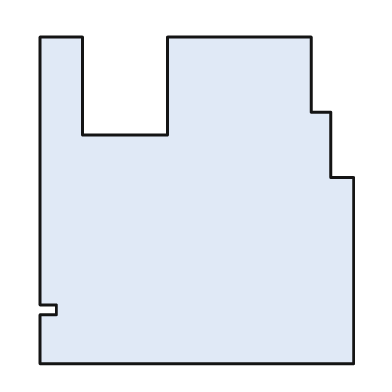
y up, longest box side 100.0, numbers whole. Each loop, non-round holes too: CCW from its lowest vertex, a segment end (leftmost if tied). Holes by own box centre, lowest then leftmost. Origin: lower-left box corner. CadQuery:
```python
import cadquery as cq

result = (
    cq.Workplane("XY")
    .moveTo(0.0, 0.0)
    .lineTo(96.0, 0.0)
    .lineTo(96.0, 57.0)
    .lineTo(89.0, 57.0)
    .lineTo(89.0, 77.0)
    .lineTo(83.0, 77.0)
    .lineTo(83.0, 100.0)
    .lineTo(39.0, 100.0)
    .lineTo(39.0, 70.0)
    .lineTo(13.0, 70.0)
    .lineTo(13.0, 100.0)
    .lineTo(0.0, 100.0)
    .lineTo(0.0, 18.0)
    .lineTo(5.0, 18.0)
    .lineTo(5.0, 15.0)
    .lineTo(0.0, 15.0)
    .close()
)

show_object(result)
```